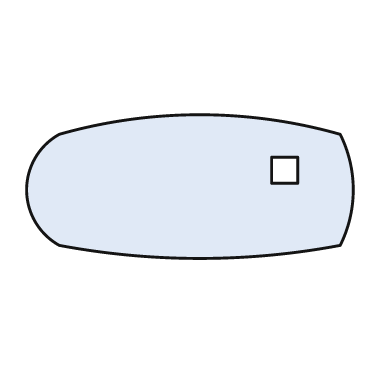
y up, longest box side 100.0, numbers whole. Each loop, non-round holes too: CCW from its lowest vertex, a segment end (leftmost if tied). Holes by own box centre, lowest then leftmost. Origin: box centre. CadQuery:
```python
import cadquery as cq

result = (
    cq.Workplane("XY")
    .moveTo(-40.0, -18.0)
    .threePointArc((3.0, -22.0), (46.0, -18.0))
    .threePointArc((50.0, -1.0), (46.0, 16.0))
    .threePointArc((3.0, 22.0), (-40.0, 16.0))
    .threePointArc((-50.0, -1.0), (-40.0, -18.0))
    .close()
    .moveTo(25.0, 1.0)
    .lineTo(33.0, 1.0)
    .lineTo(33.0, 9.0)
    .lineTo(25.0, 9.0)
    .close()
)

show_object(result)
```